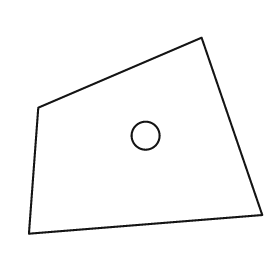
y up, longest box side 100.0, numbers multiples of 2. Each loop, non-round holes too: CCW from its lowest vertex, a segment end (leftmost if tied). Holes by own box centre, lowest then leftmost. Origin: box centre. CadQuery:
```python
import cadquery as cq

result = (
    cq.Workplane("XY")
    .moveTo(-50.0, -42.0)
    .lineTo(50.0, -34.0)
    .lineTo(24.0, 42.0)
    .lineTo(-46.0, 12.0)
    .close()
    .moveTo(0.0, 0.0)
    .circle(6.0)
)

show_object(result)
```